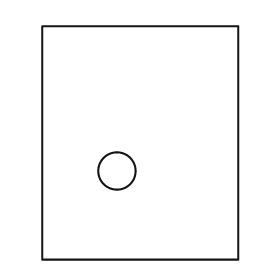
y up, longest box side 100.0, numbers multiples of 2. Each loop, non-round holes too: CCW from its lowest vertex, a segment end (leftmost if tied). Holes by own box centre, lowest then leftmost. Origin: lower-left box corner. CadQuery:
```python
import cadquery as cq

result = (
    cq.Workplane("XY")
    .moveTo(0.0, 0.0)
    .lineTo(84.0, 0.0)
    .lineTo(84.0, 100.0)
    .lineTo(0.0, 100.0)
    .close()
    .moveTo(32.0, 38.0)
    .circle(8.0)
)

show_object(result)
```